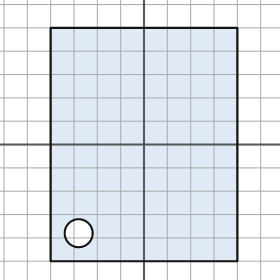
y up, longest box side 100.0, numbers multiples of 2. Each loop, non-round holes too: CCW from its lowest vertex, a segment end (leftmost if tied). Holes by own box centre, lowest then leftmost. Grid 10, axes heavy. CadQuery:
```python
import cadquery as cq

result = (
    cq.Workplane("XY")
    .moveTo(-40.0, -50.0)
    .lineTo(40.0, -50.0)
    .lineTo(40.0, 50.0)
    .lineTo(-40.0, 50.0)
    .close()
    .moveTo(-28.0, -38.0)
    .circle(6.0)
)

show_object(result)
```